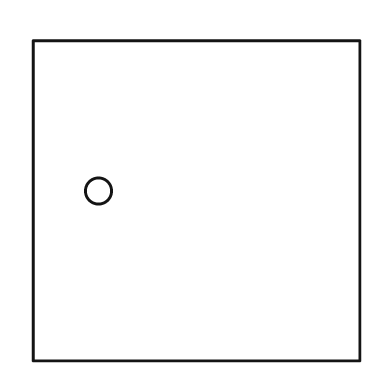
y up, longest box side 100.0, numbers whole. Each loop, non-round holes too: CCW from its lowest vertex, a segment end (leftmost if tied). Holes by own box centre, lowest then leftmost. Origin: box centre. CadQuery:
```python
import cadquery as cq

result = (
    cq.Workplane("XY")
    .moveTo(-50.0, -49.0)
    .lineTo(50.0, -49.0)
    .lineTo(50.0, 49.0)
    .lineTo(-50.0, 49.0)
    .close()
    .moveTo(-30.0, 3.0)
    .circle(4.0)
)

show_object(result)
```